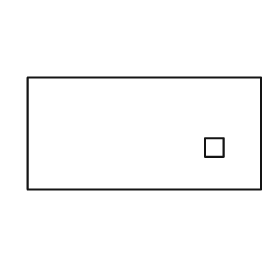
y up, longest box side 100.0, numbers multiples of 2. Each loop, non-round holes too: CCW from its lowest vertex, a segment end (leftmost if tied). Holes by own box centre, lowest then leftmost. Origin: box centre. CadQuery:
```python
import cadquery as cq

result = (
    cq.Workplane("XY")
    .moveTo(-50.0, -24.0)
    .lineTo(50.0, -24.0)
    .lineTo(50.0, 24.0)
    .lineTo(-50.0, 24.0)
    .close()
    .moveTo(26.0, -10.0)
    .lineTo(34.0, -10.0)
    .lineTo(34.0, -2.0)
    .lineTo(26.0, -2.0)
    .close()
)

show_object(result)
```